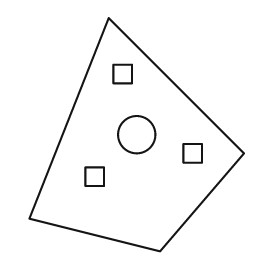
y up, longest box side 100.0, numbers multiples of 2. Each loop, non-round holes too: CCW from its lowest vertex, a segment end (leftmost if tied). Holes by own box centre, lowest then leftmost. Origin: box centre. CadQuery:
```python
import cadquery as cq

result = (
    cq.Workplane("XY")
    .moveTo(10.0, -50.0)
    .lineTo(46.0, -8.0)
    .lineTo(-12.0, 50.0)
    .lineTo(-46.0, -36.0)
    .close()
    .moveTo(-22.0, -22.0)
    .lineTo(-14.0, -22.0)
    .lineTo(-14.0, -14.0)
    .lineTo(-22.0, -14.0)
    .close()
    .moveTo(20.0, -12.0)
    .lineTo(28.0, -12.0)
    .lineTo(28.0, -4.0)
    .lineTo(20.0, -4.0)
    .close()
    .moveTo(0.0, 0.0)
    .circle(8.0)
    .moveTo(-10.0, 22.0)
    .lineTo(-2.0, 22.0)
    .lineTo(-2.0, 30.0)
    .lineTo(-10.0, 30.0)
    .close()
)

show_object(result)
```